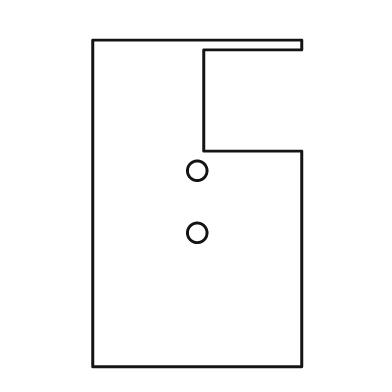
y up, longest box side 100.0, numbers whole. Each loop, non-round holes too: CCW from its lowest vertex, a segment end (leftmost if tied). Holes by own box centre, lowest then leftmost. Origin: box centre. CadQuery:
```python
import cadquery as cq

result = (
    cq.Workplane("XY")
    .moveTo(-32.0, -50.0)
    .lineTo(32.0, -50.0)
    .lineTo(32.0, 16.0)
    .lineTo(2.0, 16.0)
    .lineTo(2.0, 47.0)
    .lineTo(32.0, 47.0)
    .lineTo(32.0, 50.0)
    .lineTo(-32.0, 50.0)
    .close()
    .moveTo(0.0, -9.0)
    .circle(3.0)
    .moveTo(0.0, 10.0)
    .circle(3.0)
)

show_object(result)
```